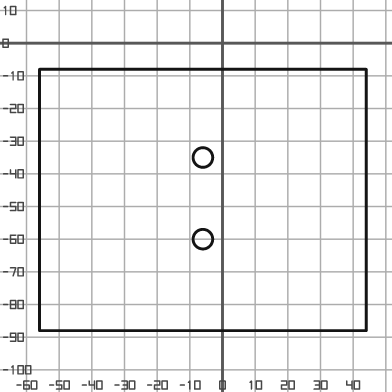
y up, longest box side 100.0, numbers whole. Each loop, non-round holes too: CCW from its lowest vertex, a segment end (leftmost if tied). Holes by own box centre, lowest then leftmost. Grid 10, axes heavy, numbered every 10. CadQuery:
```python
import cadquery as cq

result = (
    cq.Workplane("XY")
    .moveTo(-56.0, -88.0)
    .lineTo(44.0, -88.0)
    .lineTo(44.0, -8.0)
    .lineTo(-56.0, -8.0)
    .close()
    .moveTo(-6.0, -60.0)
    .circle(3.0)
    .moveTo(-6.0, -35.0)
    .circle(3.0)
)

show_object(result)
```